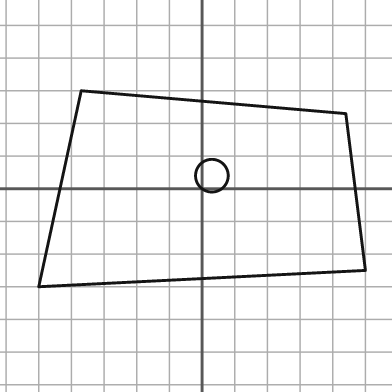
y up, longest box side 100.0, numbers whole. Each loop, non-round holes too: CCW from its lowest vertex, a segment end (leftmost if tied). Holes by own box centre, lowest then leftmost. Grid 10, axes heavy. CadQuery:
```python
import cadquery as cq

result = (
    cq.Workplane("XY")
    .moveTo(-50.0, -30.0)
    .lineTo(50.0, -25.0)
    .lineTo(44.0, 23.0)
    .lineTo(-37.0, 30.0)
    .close()
    .moveTo(3.0, 4.0)
    .circle(5.0)
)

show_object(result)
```